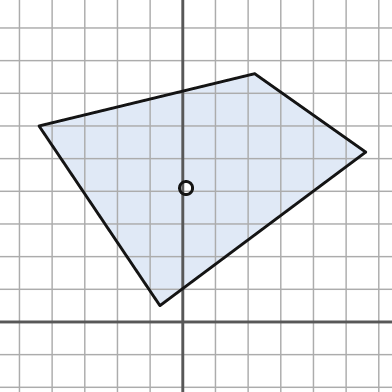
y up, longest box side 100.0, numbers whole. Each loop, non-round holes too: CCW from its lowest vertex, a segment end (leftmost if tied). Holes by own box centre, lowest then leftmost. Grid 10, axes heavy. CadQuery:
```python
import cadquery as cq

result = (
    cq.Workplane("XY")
    .moveTo(-7.0, 5.0)
    .lineTo(56.0, 52.0)
    .lineTo(22.0, 76.0)
    .lineTo(-44.0, 60.0)
    .close()
    .moveTo(1.0, 41.0)
    .circle(2.0)
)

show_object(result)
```